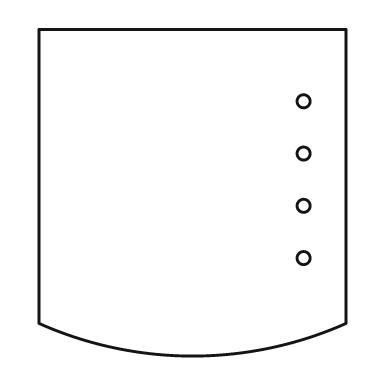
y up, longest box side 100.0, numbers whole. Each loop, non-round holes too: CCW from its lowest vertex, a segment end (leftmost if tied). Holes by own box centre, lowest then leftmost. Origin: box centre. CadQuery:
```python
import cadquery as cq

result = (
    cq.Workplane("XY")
    .moveTo(-47.0, -40.0)
    .threePointArc((0.0, -50.0), (47.0, -40.0))
    .lineTo(47.0, 50.0)
    .lineTo(-47.0, 50.0)
    .close()
    .moveTo(34.0, -20.0)
    .circle(2.0)
    .moveTo(34.0, -4.0)
    .circle(2.0)
    .moveTo(34.0, 12.0)
    .circle(2.0)
    .moveTo(34.0, 28.0)
    .circle(2.0)
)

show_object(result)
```